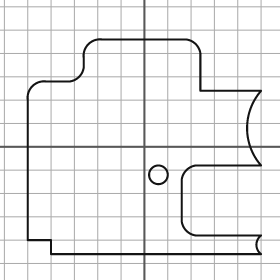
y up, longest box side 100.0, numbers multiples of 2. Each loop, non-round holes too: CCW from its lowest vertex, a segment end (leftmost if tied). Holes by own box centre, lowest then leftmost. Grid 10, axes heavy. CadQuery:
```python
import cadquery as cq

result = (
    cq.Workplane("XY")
    .moveTo(-40.0, -46.0)
    .lineTo(50.0, -46.0)
    .threePointArc((48.0, -42.0), (50.0, -38.0))
    .lineTo(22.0, -38.0)
    .threePointArc((18.0, -36.0), (16.0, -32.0))
    .lineTo(16.0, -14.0)
    .threePointArc((18.0, -10.0), (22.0, -8.0))
    .lineTo(50.0, -8.0)
    .threePointArc((44.0, 8.0), (50.0, 24.0))
    .lineTo(24.0, 24.0)
    .lineTo(24.0, 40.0)
    .threePointArc((22.0, 44.0), (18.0, 46.0))
    .lineTo(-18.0, 46.0)
    .threePointArc((-24.0, 44.0), (-26.0, 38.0))
    .lineTo(-26.0, 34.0)
    .threePointArc((-28.0, 30.0), (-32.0, 28.0))
    .lineTo(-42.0, 28.0)
    .threePointArc((-48.0, 26.0), (-50.0, 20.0))
    .lineTo(-50.0, -40.0)
    .lineTo(-40.0, -40.0)
    .close()
    .moveTo(6.0, -12.0)
    .circle(4.0)
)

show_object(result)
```